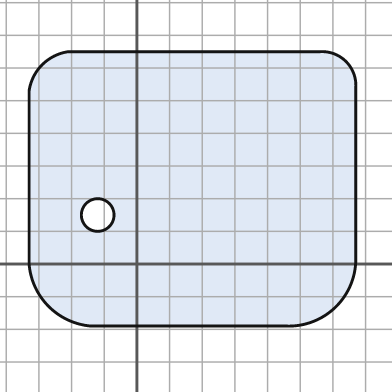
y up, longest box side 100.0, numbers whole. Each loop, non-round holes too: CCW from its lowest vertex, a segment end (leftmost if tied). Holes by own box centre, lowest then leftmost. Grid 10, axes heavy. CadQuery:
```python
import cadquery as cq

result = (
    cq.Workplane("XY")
    .moveTo(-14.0, -19.0)
    .lineTo(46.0, -19.0)
    .threePointArc((61.0, -13.0), (67.0, 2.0))
    .lineTo(67.0, 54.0)
    .threePointArc((64.0, 62.0), (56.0, 65.0))
    .lineTo(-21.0, 65.0)
    .threePointArc((-29.0, 61.0), (-33.0, 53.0))
    .lineTo(-33.0, 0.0)
    .threePointArc((-27.0, -13.0), (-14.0, -19.0))
    .close()
    .moveTo(-12.0, 15.0)
    .circle(5.0)
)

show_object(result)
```